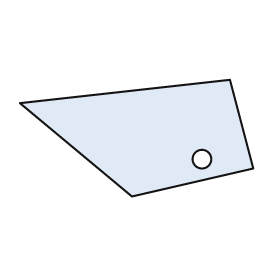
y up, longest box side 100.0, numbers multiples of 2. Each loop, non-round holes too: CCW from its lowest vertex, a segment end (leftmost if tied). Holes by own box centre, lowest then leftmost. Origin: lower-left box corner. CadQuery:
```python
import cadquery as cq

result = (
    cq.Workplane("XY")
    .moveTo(48.0, 0.0)
    .lineTo(100.0, 12.0)
    .lineTo(90.0, 50.0)
    .lineTo(0.0, 40.0)
    .close()
    .moveTo(78.0, 16.0)
    .circle(4.0)
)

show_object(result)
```